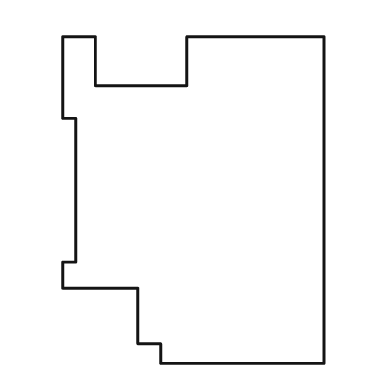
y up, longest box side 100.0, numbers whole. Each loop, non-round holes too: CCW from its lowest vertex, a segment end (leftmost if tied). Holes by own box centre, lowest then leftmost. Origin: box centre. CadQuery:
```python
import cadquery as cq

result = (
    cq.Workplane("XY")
    .moveTo(-10.0, -50.0)
    .lineTo(40.0, -50.0)
    .lineTo(40.0, 50.0)
    .lineTo(-2.0, 50.0)
    .lineTo(-2.0, 35.0)
    .lineTo(-30.0, 35.0)
    .lineTo(-30.0, 50.0)
    .lineTo(-40.0, 50.0)
    .lineTo(-40.0, 25.0)
    .lineTo(-36.0, 25.0)
    .lineTo(-36.0, -19.0)
    .lineTo(-40.0, -19.0)
    .lineTo(-40.0, -27.0)
    .lineTo(-17.0, -27.0)
    .lineTo(-17.0, -44.0)
    .lineTo(-10.0, -44.0)
    .close()
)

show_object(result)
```